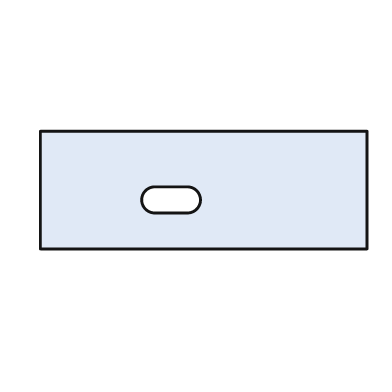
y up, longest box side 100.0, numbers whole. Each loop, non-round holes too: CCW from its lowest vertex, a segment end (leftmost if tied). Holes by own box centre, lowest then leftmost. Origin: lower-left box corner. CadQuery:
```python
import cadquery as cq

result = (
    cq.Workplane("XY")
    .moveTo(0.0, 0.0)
    .lineTo(100.0, 0.0)
    .lineTo(100.0, 36.0)
    .lineTo(0.0, 36.0)
    .close()
    .moveTo(35.0, 11.0)
    .lineTo(45.0, 11.0)
    .threePointArc((49.0, 15.0), (45.0, 19.0))
    .lineTo(35.0, 19.0)
    .threePointArc((31.0, 15.0), (35.0, 11.0))
    .close()
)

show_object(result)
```